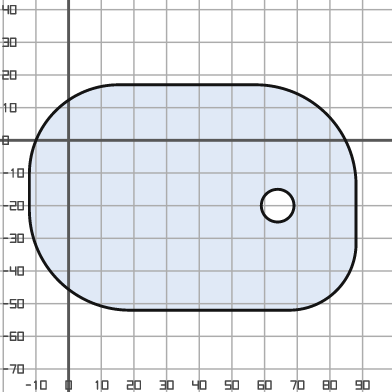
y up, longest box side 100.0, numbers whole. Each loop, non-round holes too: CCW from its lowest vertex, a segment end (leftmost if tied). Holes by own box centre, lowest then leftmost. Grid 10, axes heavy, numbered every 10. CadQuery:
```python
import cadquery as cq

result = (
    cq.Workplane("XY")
    .moveTo(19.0, -52.0)
    .lineTo(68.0, -52.0)
    .threePointArc((82.0, -46.0), (88.0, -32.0))
    .lineTo(88.0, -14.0)
    .threePointArc((79.0, 8.0), (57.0, 17.0))
    .lineTo(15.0, 17.0)
    .threePointArc((-4.0, 9.0), (-12.0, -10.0))
    .lineTo(-12.0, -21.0)
    .threePointArc((-3.0, -43.0), (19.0, -52.0))
    .close()
    .moveTo(64.0, -20.0)
    .circle(5.0)
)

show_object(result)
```